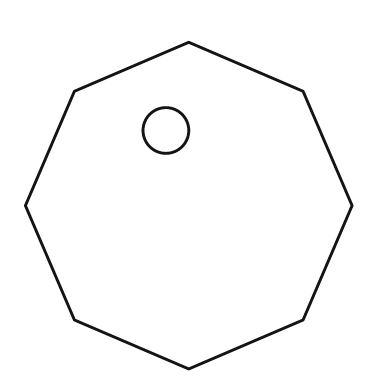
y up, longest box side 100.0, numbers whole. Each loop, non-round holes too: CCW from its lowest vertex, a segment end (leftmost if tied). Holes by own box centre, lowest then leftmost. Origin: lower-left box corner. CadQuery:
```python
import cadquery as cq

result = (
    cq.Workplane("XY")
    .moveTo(50.0, 0.0)
    .lineTo(85.0, 15.0)
    .lineTo(100.0, 50.0)
    .lineTo(85.0, 85.0)
    .lineTo(50.0, 100.0)
    .lineTo(15.0, 85.0)
    .lineTo(0.0, 50.0)
    .lineTo(15.0, 15.0)
    .close()
    .moveTo(43.0, 73.0)
    .circle(7.0)
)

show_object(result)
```